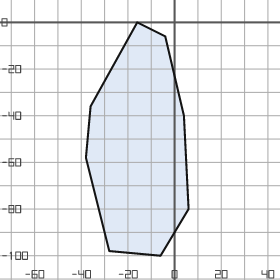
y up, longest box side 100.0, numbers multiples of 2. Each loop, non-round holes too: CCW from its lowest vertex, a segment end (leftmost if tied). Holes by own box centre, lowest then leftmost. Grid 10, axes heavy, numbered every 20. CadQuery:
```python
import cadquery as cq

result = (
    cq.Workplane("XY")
    .moveTo(-6.0, -100.0)
    .lineTo(6.0, -80.0)
    .lineTo(4.0, -40.0)
    .lineTo(-4.0, -6.0)
    .lineTo(-16.0, 0.0)
    .lineTo(-36.0, -36.0)
    .lineTo(-38.0, -58.0)
    .lineTo(-28.0, -98.0)
    .close()
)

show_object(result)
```